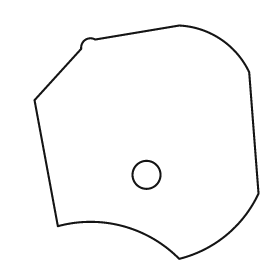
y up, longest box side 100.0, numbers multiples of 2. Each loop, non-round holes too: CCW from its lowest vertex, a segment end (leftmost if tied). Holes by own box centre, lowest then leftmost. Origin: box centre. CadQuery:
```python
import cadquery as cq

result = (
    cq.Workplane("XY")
    .moveTo(14.0, -50.0)
    .threePointArc((34.0, -40.0), (48.0, -22.0))
    .lineTo(44.0, 30.0)
    .threePointArc((32.0, 44.0), (14.0, 50.0))
    .lineTo(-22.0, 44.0)
    .threePointArc((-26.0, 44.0), (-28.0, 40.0))
    .lineTo(-48.0, 18.0)
    .lineTo(-38.0, -36.0)
    .threePointArc((-10.0, -36.0), (14.0, -50.0))
    .close()
    .moveTo(0.0, -14.0)
    .circle(6.0)
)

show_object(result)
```